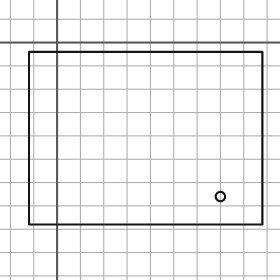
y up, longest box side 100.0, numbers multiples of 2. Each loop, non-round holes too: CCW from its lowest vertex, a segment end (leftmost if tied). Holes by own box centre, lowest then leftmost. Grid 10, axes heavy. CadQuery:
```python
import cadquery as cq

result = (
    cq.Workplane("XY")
    .moveTo(-12.0, -78.0)
    .lineTo(88.0, -78.0)
    .lineTo(88.0, -4.0)
    .lineTo(-12.0, -4.0)
    .close()
    .moveTo(70.0, -66.0)
    .circle(2.0)
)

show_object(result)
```